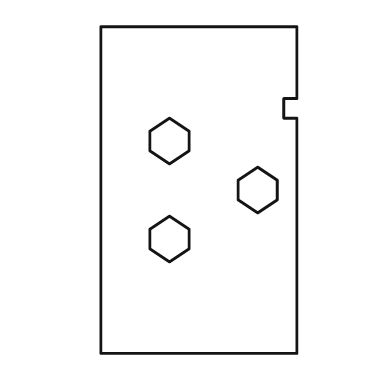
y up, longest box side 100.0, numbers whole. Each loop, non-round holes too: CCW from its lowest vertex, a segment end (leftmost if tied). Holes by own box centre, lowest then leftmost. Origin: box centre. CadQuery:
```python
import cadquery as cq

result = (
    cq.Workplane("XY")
    .moveTo(-30.0, -50.0)
    .lineTo(30.0, -50.0)
    .lineTo(30.0, 22.0)
    .lineTo(26.0, 22.0)
    .lineTo(26.0, 28.0)
    .lineTo(30.0, 28.0)
    .lineTo(30.0, 50.0)
    .lineTo(-30.0, 50.0)
    .close()
    .moveTo(-9.0, -22.0)
    .lineTo(-3.0, -18.0)
    .lineTo(-3.0, -12.0)
    .lineTo(-9.0, -8.0)
    .lineTo(-15.0, -12.0)
    .lineTo(-15.0, -18.0)
    .close()
    .moveTo(18.0, -7.0)
    .lineTo(24.0, -3.0)
    .lineTo(24.0, 3.0)
    .lineTo(18.0, 7.0)
    .lineTo(12.0, 3.0)
    .lineTo(12.0, -3.0)
    .close()
    .moveTo(-9.0, 8.0)
    .lineTo(-3.0, 12.0)
    .lineTo(-3.0, 18.0)
    .lineTo(-9.0, 22.0)
    .lineTo(-15.0, 18.0)
    .lineTo(-15.0, 12.0)
    .close()
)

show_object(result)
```